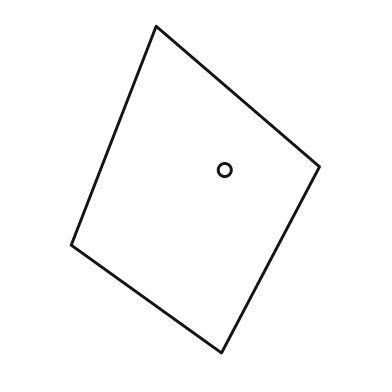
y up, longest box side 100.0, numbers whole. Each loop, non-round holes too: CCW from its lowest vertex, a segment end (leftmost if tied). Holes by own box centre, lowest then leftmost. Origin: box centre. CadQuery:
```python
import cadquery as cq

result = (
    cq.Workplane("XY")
    .moveTo(8.0, -50.0)
    .lineTo(38.0, 7.0)
    .lineTo(-12.0, 50.0)
    .lineTo(-38.0, -17.0)
    .close()
    .moveTo(9.0, 6.0)
    .circle(2.0)
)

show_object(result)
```